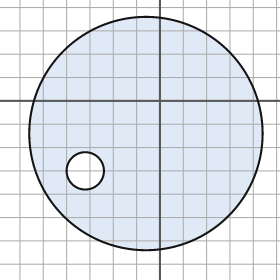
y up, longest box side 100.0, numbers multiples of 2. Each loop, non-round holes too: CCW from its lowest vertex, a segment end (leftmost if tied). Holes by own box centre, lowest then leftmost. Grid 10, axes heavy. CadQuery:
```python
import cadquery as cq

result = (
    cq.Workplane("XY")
    .moveTo(-6.0, -14.0)
    .circle(50.0)
    .moveTo(-32.0, -30.0)
    .circle(8.0)
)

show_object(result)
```